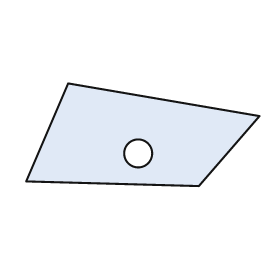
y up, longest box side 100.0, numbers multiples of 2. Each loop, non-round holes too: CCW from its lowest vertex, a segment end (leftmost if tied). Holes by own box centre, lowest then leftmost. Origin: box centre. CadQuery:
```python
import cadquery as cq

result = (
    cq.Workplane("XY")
    .moveTo(24.0, -22.0)
    .lineTo(50.0, 8.0)
    .lineTo(-32.0, 22.0)
    .lineTo(-50.0, -20.0)
    .close()
    .moveTo(-2.0, -8.0)
    .circle(6.0)
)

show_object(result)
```